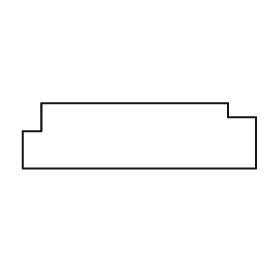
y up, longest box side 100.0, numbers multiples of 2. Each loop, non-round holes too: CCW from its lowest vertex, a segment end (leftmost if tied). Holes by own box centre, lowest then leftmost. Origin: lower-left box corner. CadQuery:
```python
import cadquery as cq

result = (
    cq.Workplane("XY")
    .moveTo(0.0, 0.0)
    .lineTo(100.0, 0.0)
    .lineTo(100.0, 22.0)
    .lineTo(88.0, 22.0)
    .lineTo(88.0, 28.0)
    .lineTo(8.0, 28.0)
    .lineTo(8.0, 16.0)
    .lineTo(0.0, 16.0)
    .close()
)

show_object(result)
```